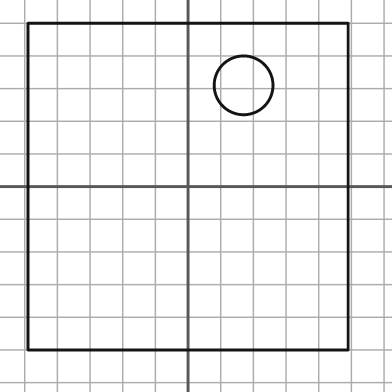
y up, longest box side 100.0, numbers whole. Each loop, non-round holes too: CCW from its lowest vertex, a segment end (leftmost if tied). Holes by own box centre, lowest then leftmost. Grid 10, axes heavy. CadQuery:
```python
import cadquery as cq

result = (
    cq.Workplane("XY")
    .moveTo(-49.0, -50.0)
    .lineTo(49.0, -50.0)
    .lineTo(49.0, 50.0)
    .lineTo(-49.0, 50.0)
    .close()
    .moveTo(17.0, 31.0)
    .circle(9.0)
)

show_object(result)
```